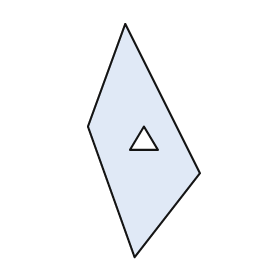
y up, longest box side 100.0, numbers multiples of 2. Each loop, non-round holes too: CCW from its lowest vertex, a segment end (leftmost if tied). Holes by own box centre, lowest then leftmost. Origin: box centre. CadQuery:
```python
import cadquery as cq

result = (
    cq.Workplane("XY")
    .moveTo(-4.0, -50.0)
    .lineTo(24.0, -14.0)
    .lineTo(-8.0, 50.0)
    .lineTo(-24.0, 6.0)
    .close()
    .moveTo(-6.0, -4.0)
    .lineTo(6.0, -4.0)
    .lineTo(0.0, 6.0)
    .close()
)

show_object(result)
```